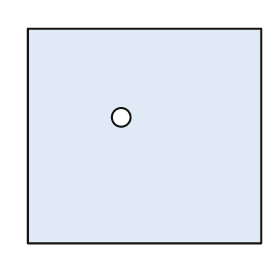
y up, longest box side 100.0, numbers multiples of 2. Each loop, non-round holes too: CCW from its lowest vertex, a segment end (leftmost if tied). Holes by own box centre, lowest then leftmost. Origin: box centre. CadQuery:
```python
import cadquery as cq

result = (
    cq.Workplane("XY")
    .moveTo(-50.0, -46.0)
    .lineTo(50.0, -46.0)
    .lineTo(50.0, 46.0)
    .lineTo(-50.0, 46.0)
    .close()
    .moveTo(-10.0, 8.0)
    .circle(4.0)
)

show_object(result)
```